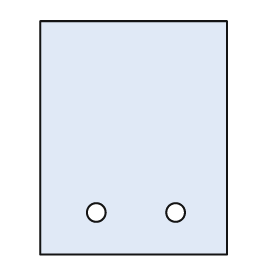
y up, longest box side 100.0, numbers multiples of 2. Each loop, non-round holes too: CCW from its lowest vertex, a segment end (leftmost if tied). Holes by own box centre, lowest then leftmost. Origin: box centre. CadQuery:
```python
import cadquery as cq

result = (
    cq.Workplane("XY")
    .moveTo(-40.0, -50.0)
    .lineTo(40.0, -50.0)
    .lineTo(40.0, 50.0)
    .lineTo(-40.0, 50.0)
    .close()
    .moveTo(-16.0, -32.0)
    .circle(4.0)
    .moveTo(18.0, -32.0)
    .circle(4.0)
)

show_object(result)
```